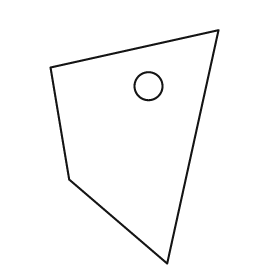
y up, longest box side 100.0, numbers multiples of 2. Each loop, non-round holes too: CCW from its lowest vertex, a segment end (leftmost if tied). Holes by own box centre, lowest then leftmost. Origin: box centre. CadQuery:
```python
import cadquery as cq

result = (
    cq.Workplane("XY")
    .moveTo(14.0, -50.0)
    .lineTo(36.0, 50.0)
    .lineTo(-36.0, 34.0)
    .lineTo(-28.0, -14.0)
    .close()
    .moveTo(6.0, 26.0)
    .circle(6.0)
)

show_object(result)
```